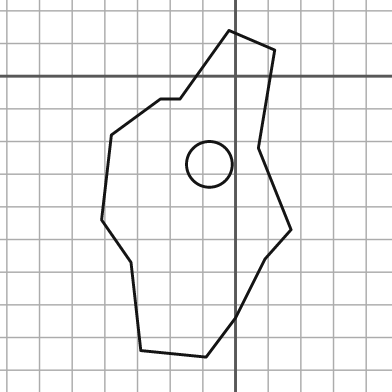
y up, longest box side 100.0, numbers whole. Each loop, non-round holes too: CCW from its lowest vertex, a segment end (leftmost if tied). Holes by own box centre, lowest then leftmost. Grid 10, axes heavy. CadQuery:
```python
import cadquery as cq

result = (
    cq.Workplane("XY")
    .moveTo(-9.0, -86.0)
    .lineTo(0.0, -74.0)
    .lineTo(9.0, -56.0)
    .lineTo(17.0, -47.0)
    .lineTo(7.0, -22.0)
    .lineTo(12.0, 8.0)
    .lineTo(-2.0, 14.0)
    .lineTo(-17.0, -7.0)
    .lineTo(-23.0, -7.0)
    .lineTo(-38.0, -18.0)
    .lineTo(-41.0, -44.0)
    .lineTo(-32.0, -57.0)
    .lineTo(-29.0, -84.0)
    .close()
    .moveTo(-8.0, -27.0)
    .circle(7.0)
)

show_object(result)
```